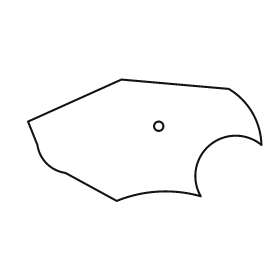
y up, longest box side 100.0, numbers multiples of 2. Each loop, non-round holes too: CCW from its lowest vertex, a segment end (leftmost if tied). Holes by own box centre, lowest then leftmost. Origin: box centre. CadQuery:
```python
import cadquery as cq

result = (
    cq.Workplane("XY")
    .moveTo(-12.0, -26.0)
    .threePointArc((6.0, -22.0), (24.0, -24.0))
    .threePointArc((28.0, -2.0), (50.0, -2.0))
    .threePointArc((46.0, 12.0), (36.0, 22.0))
    .lineTo(-10.0, 26.0)
    .lineTo(-50.0, 8.0)
    .lineTo(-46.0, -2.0)
    .threePointArc((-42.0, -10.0), (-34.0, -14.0))
    .close()
    .moveTo(6.0, 6.0)
    .circle(2.0)
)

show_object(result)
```